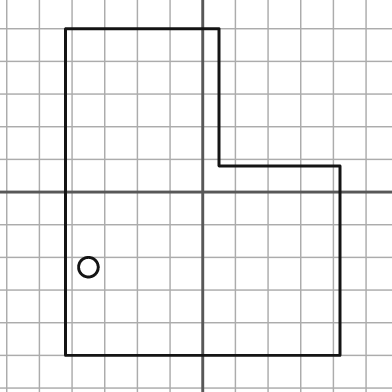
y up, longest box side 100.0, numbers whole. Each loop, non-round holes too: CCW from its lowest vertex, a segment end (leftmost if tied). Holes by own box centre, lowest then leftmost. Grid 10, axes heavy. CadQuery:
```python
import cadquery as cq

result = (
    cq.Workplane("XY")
    .moveTo(-42.0, -50.0)
    .lineTo(42.0, -50.0)
    .lineTo(42.0, 8.0)
    .lineTo(5.0, 8.0)
    .lineTo(5.0, 50.0)
    .lineTo(-42.0, 50.0)
    .close()
    .moveTo(-35.0, -23.0)
    .circle(3.0)
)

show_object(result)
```